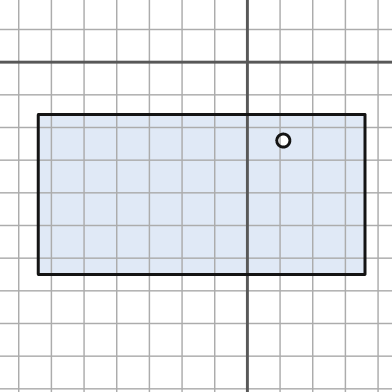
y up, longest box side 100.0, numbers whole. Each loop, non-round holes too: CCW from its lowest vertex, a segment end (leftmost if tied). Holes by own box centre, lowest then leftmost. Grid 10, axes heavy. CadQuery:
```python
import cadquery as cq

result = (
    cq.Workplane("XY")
    .moveTo(-64.0, -65.0)
    .lineTo(36.0, -65.0)
    .lineTo(36.0, -16.0)
    .lineTo(-64.0, -16.0)
    .close()
    .moveTo(11.0, -24.0)
    .circle(2.0)
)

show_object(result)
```